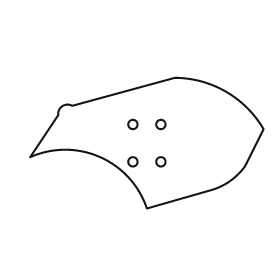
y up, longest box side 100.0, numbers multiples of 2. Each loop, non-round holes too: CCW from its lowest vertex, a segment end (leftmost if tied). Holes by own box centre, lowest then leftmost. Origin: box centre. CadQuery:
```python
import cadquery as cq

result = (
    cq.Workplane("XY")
    .moveTo(0.0, -28.0)
    .lineTo(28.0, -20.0)
    .threePointArc((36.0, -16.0), (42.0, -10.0))
    .lineTo(50.0, 6.0)
    .threePointArc((34.0, 22.0), (12.0, 28.0))
    .lineTo(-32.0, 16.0)
    .threePointArc((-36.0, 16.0), (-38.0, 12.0))
    .lineTo(-50.0, -6.0)
    .threePointArc((-20.0, -6.0), (0.0, -28.0))
    .close()
    .moveTo(-6.0, -8.0)
    .circle(2.0)
    .moveTo(6.0, -8.0)
    .circle(2.0)
    .moveTo(-6.0, 8.0)
    .circle(2.0)
    .moveTo(6.0, 8.0)
    .circle(2.0)
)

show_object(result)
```